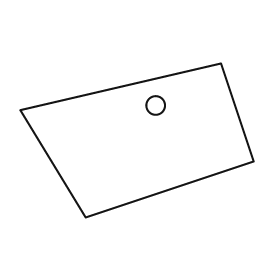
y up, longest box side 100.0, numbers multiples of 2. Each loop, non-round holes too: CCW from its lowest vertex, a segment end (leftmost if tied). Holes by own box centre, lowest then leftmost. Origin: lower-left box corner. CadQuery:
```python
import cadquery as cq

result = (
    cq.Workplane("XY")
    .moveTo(28.0, 0.0)
    .lineTo(100.0, 24.0)
    .lineTo(86.0, 66.0)
    .lineTo(0.0, 46.0)
    .close()
    .moveTo(58.0, 48.0)
    .circle(4.0)
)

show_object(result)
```